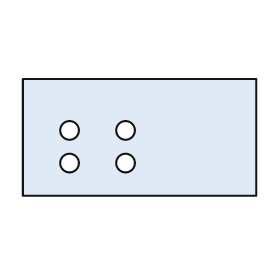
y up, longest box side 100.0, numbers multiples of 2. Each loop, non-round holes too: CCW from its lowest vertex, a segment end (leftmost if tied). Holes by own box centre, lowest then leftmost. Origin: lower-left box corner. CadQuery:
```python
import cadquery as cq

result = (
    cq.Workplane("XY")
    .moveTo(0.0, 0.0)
    .lineTo(100.0, 0.0)
    .lineTo(100.0, 50.0)
    .lineTo(0.0, 50.0)
    .close()
    .moveTo(20.0, 14.0)
    .circle(4.0)
    .moveTo(44.0, 14.0)
    .circle(4.0)
    .moveTo(20.0, 28.0)
    .circle(4.0)
    .moveTo(44.0, 28.0)
    .circle(4.0)
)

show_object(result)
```